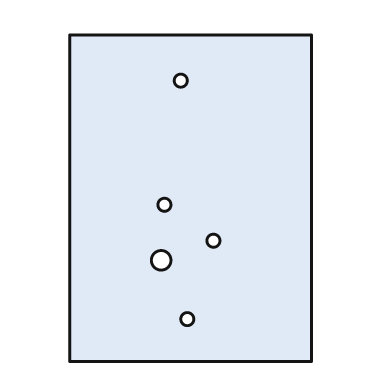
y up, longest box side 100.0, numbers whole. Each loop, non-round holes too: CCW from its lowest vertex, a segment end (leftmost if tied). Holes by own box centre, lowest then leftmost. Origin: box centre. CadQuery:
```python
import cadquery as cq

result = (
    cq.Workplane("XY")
    .moveTo(-37.0, -50.0)
    .lineTo(37.0, -50.0)
    .lineTo(37.0, 50.0)
    .lineTo(-37.0, 50.0)
    .close()
    .moveTo(-1.0, -37.0)
    .circle(2.0)
    .moveTo(-9.0, -19.0)
    .circle(3.0)
    .moveTo(7.0, -13.0)
    .circle(2.0)
    .moveTo(-8.0, -2.0)
    .circle(2.0)
    .moveTo(-3.0, 36.0)
    .circle(2.0)
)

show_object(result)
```